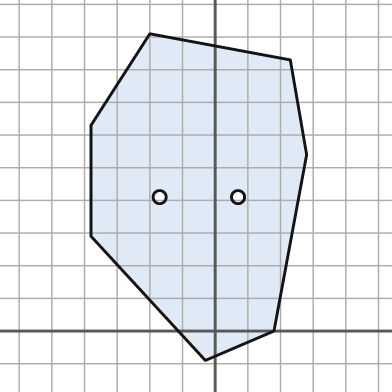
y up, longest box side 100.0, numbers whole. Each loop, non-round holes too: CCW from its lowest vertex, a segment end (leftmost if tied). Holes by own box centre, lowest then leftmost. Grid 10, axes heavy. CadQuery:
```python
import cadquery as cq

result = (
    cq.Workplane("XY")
    .moveTo(-3.0, -9.0)
    .lineTo(18.0, 0.0)
    .lineTo(28.0, 54.0)
    .lineTo(23.0, 83.0)
    .lineTo(-20.0, 91.0)
    .lineTo(-38.0, 63.0)
    .lineTo(-38.0, 29.0)
    .close()
    .moveTo(-17.0, 41.0)
    .circle(2.0)
    .moveTo(7.0, 41.0)
    .circle(2.0)
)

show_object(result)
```